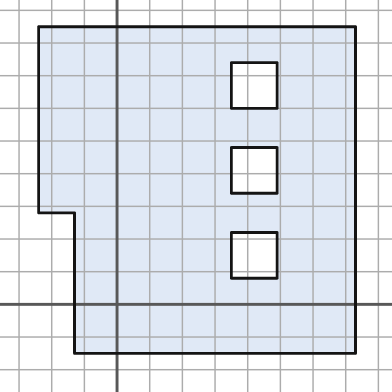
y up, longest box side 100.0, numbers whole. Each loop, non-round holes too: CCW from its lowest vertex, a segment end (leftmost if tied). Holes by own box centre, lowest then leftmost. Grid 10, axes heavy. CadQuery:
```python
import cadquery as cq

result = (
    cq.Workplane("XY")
    .moveTo(-13.0, -15.0)
    .lineTo(73.0, -15.0)
    .lineTo(73.0, 85.0)
    .lineTo(-24.0, 85.0)
    .lineTo(-24.0, 28.0)
    .lineTo(-13.0, 28.0)
    .close()
    .moveTo(35.0, 8.0)
    .lineTo(49.0, 8.0)
    .lineTo(49.0, 22.0)
    .lineTo(35.0, 22.0)
    .close()
    .moveTo(35.0, 34.0)
    .lineTo(49.0, 34.0)
    .lineTo(49.0, 48.0)
    .lineTo(35.0, 48.0)
    .close()
    .moveTo(35.0, 60.0)
    .lineTo(49.0, 60.0)
    .lineTo(49.0, 74.0)
    .lineTo(35.0, 74.0)
    .close()
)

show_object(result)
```